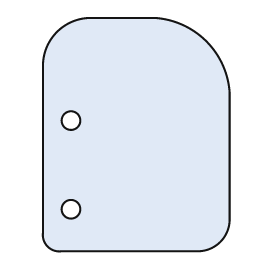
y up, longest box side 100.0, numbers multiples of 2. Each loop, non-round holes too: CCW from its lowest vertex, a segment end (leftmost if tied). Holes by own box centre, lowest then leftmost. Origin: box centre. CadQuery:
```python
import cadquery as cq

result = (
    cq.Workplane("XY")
    .moveTo(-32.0, -50.0)
    .lineTo(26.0, -50.0)
    .threePointArc((36.0, -46.0), (40.0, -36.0))
    .lineTo(40.0, 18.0)
    .threePointArc((30.0, 40.0), (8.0, 50.0))
    .lineTo(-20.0, 50.0)
    .threePointArc((-34.0, 44.0), (-40.0, 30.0))
    .lineTo(-40.0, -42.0)
    .threePointArc((-38.0, -48.0), (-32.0, -50.0))
    .close()
    .moveTo(-28.0, -32.0)
    .circle(4.0)
    .moveTo(-28.0, 6.0)
    .circle(4.0)
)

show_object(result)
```